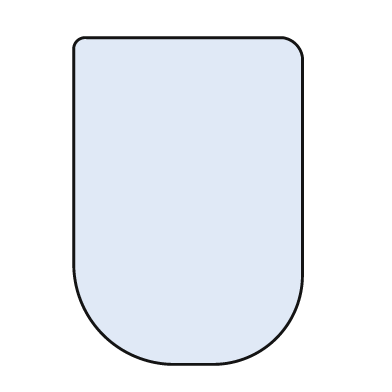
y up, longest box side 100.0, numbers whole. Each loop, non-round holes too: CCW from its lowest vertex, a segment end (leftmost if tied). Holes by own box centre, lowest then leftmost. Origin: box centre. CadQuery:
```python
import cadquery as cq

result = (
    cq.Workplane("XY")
    .moveTo(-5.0, -50.0)
    .lineTo(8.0, -50.0)
    .threePointArc((27.0, -42.0), (35.0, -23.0))
    .lineTo(35.0, 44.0)
    .threePointArc((33.0, 48.0), (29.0, 50.0))
    .lineTo(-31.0, 50.0)
    .threePointArc((-34.0, 49.0), (-35.0, 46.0))
    .lineTo(-35.0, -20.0)
    .threePointArc((-26.0, -41.0), (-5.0, -50.0))
    .close()
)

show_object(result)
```